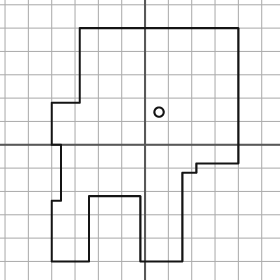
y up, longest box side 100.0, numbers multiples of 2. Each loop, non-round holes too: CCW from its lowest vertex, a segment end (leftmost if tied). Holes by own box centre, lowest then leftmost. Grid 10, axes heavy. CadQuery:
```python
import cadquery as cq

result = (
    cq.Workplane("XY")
    .moveTo(-40.0, -50.0)
    .lineTo(-24.0, -50.0)
    .lineTo(-24.0, -22.0)
    .lineTo(-2.0, -22.0)
    .lineTo(-2.0, -50.0)
    .lineTo(16.0, -50.0)
    .lineTo(16.0, -12.0)
    .lineTo(22.0, -12.0)
    .lineTo(22.0, -8.0)
    .lineTo(40.0, -8.0)
    .lineTo(40.0, 50.0)
    .lineTo(-28.0, 50.0)
    .lineTo(-28.0, 18.0)
    .lineTo(-40.0, 18.0)
    .lineTo(-40.0, 0.0)
    .lineTo(-36.0, 0.0)
    .lineTo(-36.0, -24.0)
    .lineTo(-40.0, -24.0)
    .close()
    .moveTo(6.0, 14.0)
    .circle(2.0)
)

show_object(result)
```